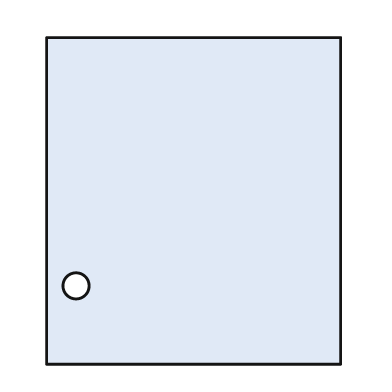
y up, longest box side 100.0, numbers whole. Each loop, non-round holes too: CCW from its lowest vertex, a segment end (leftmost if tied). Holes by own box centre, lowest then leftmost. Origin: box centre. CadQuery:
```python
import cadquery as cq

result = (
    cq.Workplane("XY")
    .moveTo(-45.0, -50.0)
    .lineTo(45.0, -50.0)
    .lineTo(45.0, 50.0)
    .lineTo(-45.0, 50.0)
    .close()
    .moveTo(-36.0, -26.0)
    .circle(4.0)
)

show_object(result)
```